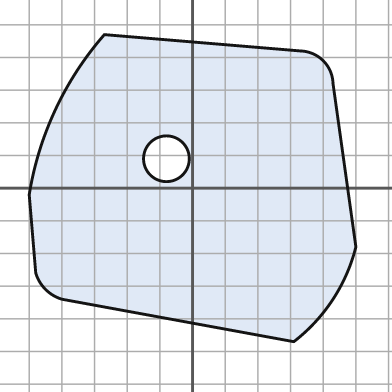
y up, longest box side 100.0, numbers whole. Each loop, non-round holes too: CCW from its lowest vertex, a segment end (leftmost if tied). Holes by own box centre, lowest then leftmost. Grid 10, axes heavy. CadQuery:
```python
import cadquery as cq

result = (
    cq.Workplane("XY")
    .moveTo(31.0, -47.0)
    .threePointArc((43.0, -34.0), (50.0, -18.0))
    .lineTo(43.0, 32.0)
    .threePointArc((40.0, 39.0), (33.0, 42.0))
    .lineTo(-27.0, 47.0)
    .threePointArc((-42.0, 24.0), (-50.0, -2.0))
    .lineTo(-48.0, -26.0)
    .threePointArc((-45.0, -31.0), (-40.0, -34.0))
    .close()
    .moveTo(-8.0, 9.0)
    .circle(7.0)
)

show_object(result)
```